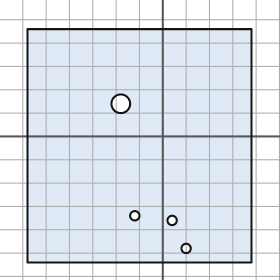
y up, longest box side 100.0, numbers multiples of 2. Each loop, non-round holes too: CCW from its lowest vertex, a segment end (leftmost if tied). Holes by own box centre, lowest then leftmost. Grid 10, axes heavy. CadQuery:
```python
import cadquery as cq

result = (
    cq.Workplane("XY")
    .moveTo(-58.0, -54.0)
    .lineTo(38.0, -54.0)
    .lineTo(38.0, 46.0)
    .lineTo(-58.0, 46.0)
    .close()
    .moveTo(10.0, -48.0)
    .circle(2.0)
    .moveTo(4.0, -36.0)
    .circle(2.0)
    .moveTo(-12.0, -34.0)
    .circle(2.0)
    .moveTo(-18.0, 14.0)
    .circle(4.0)
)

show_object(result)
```